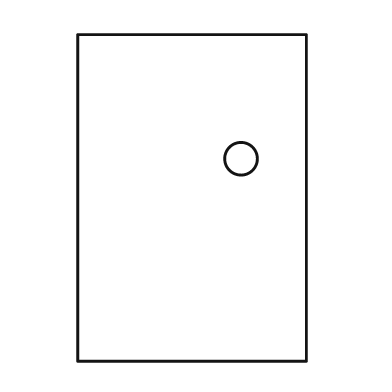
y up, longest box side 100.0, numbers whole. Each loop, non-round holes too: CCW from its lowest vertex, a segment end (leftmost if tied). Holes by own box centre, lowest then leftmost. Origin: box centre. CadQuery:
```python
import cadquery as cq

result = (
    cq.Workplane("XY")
    .moveTo(-35.0, -50.0)
    .lineTo(35.0, -50.0)
    .lineTo(35.0, 50.0)
    .lineTo(-35.0, 50.0)
    .close()
    .moveTo(15.0, 12.0)
    .circle(5.0)
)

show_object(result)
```